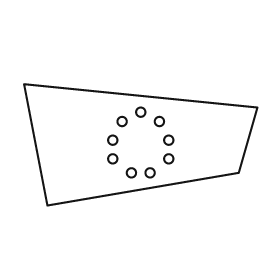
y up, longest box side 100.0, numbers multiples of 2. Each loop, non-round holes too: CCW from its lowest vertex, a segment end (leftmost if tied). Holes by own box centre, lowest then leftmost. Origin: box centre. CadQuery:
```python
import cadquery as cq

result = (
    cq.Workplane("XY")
    .moveTo(-40.0, -26.0)
    .lineTo(42.0, -12.0)
    .lineTo(50.0, 16.0)
    .lineTo(-50.0, 26.0)
    .close()
    .moveTo(-4.0, -12.0)
    .circle(2.0)
    .moveTo(4.0, -12.0)
    .circle(2.0)
    .moveTo(-12.0, -6.0)
    .circle(2.0)
    .moveTo(12.0, -6.0)
    .circle(2.0)
    .moveTo(-12.0, 2.0)
    .circle(2.0)
    .moveTo(12.0, 2.0)
    .circle(2.0)
    .moveTo(-8.0, 10.0)
    .circle(2.0)
    .moveTo(8.0, 10.0)
    .circle(2.0)
    .moveTo(0.0, 14.0)
    .circle(2.0)
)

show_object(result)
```